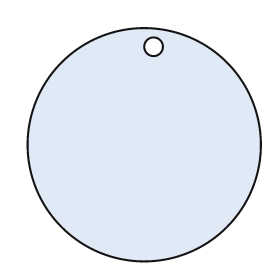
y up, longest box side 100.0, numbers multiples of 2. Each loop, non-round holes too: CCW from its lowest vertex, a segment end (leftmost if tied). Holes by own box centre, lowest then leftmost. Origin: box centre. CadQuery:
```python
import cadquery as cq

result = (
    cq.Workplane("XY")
    .moveTo(0.0, 0.0)
    .circle(50.0)
    .moveTo(4.0, 42.0)
    .circle(4.0)
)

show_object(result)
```